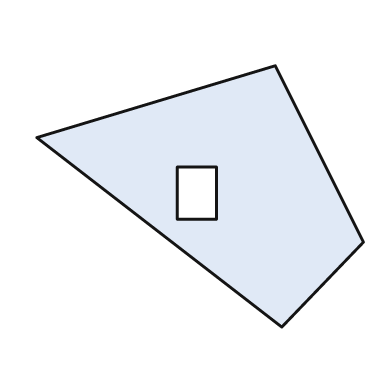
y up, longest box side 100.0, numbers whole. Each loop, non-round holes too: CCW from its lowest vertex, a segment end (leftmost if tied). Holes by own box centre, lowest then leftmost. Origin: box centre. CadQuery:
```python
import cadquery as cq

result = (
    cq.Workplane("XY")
    .moveTo(25.0, -40.0)
    .lineTo(50.0, -14.0)
    .lineTo(23.0, 40.0)
    .lineTo(-50.0, 18.0)
    .close()
    .moveTo(-7.0, -7.0)
    .lineTo(5.0, -7.0)
    .lineTo(5.0, 9.0)
    .lineTo(-7.0, 9.0)
    .close()
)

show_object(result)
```